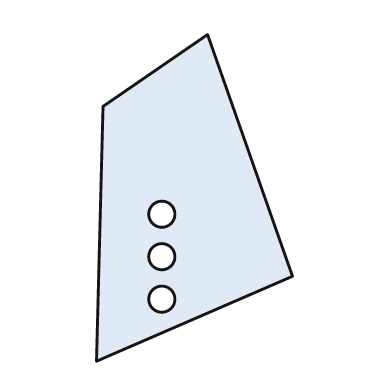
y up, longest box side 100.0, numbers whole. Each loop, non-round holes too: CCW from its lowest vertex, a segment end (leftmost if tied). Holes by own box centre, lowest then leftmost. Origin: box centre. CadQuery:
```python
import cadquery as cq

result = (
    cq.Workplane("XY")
    .moveTo(-30.0, -50.0)
    .lineTo(30.0, -24.0)
    .lineTo(4.0, 50.0)
    .lineTo(-28.0, 28.0)
    .close()
    .moveTo(-10.0, -31.0)
    .circle(4.0)
    .moveTo(-10.0, -18.0)
    .circle(4.0)
    .moveTo(-10.0, -5.0)
    .circle(4.0)
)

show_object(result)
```